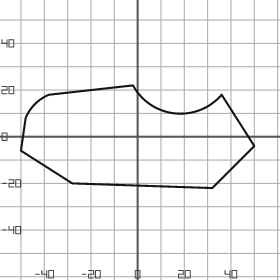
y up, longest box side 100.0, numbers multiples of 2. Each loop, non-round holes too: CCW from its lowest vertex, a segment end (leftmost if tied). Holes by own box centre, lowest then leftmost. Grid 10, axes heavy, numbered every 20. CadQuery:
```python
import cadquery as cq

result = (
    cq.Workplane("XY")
    .moveTo(32.0, -22.0)
    .lineTo(50.0, -4.0)
    .lineTo(36.0, 18.0)
    .threePointArc((16.0, 10.0), (-2.0, 22.0))
    .lineTo(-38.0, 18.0)
    .threePointArc((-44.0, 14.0), (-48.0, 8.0))
    .lineTo(-50.0, -6.0)
    .lineTo(-28.0, -20.0)
    .close()
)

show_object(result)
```